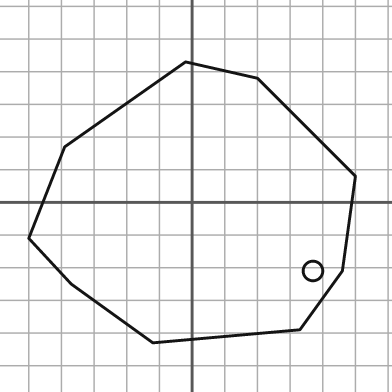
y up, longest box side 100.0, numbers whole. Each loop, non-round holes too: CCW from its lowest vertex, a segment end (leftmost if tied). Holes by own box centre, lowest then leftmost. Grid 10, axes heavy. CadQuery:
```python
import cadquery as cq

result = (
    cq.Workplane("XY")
    .moveTo(-12.0, -43.0)
    .lineTo(33.0, -39.0)
    .lineTo(46.0, -21.0)
    .lineTo(50.0, 8.0)
    .lineTo(20.0, 38.0)
    .lineTo(-2.0, 43.0)
    .lineTo(-39.0, 17.0)
    .lineTo(-50.0, -11.0)
    .lineTo(-37.0, -25.0)
    .close()
    .moveTo(37.0, -21.0)
    .circle(3.0)
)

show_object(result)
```